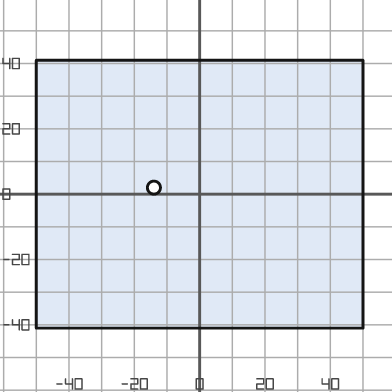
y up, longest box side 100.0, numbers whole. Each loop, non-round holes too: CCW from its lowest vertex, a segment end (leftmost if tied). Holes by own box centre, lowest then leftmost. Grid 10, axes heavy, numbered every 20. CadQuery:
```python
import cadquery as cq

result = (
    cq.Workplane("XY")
    .moveTo(-50.0, -41.0)
    .lineTo(50.0, -41.0)
    .lineTo(50.0, 41.0)
    .lineTo(-50.0, 41.0)
    .close()
    .moveTo(-14.0, 2.0)
    .circle(2.0)
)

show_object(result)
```